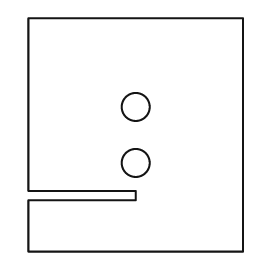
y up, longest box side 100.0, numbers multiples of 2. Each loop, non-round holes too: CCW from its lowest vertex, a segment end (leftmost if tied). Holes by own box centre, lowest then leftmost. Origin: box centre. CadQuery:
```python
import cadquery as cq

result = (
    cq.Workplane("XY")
    .moveTo(-46.0, -50.0)
    .lineTo(46.0, -50.0)
    .lineTo(46.0, 50.0)
    .lineTo(-46.0, 50.0)
    .lineTo(-46.0, -24.0)
    .lineTo(0.0, -24.0)
    .lineTo(0.0, -28.0)
    .lineTo(-46.0, -28.0)
    .close()
    .moveTo(0.0, -12.0)
    .circle(6.0)
    .moveTo(0.0, 12.0)
    .circle(6.0)
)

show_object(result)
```